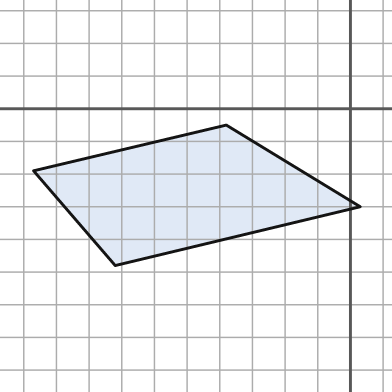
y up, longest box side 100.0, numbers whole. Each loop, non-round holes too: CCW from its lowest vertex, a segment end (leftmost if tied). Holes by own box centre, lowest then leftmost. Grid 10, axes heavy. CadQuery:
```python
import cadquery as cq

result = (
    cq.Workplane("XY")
    .moveTo(-72.0, -48.0)
    .lineTo(3.0, -30.0)
    .lineTo(-38.0, -5.0)
    .lineTo(-97.0, -19.0)
    .close()
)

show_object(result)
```